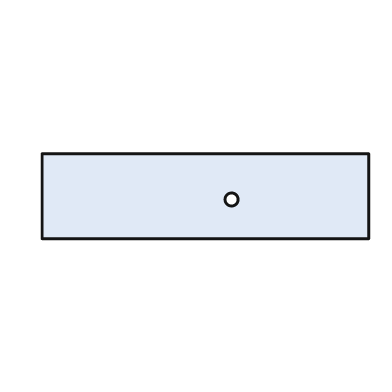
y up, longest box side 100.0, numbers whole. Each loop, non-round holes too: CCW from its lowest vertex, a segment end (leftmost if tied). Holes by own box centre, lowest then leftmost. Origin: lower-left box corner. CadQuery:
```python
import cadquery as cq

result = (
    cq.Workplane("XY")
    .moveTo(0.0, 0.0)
    .lineTo(100.0, 0.0)
    .lineTo(100.0, 26.0)
    .lineTo(0.0, 26.0)
    .close()
    .moveTo(58.0, 12.0)
    .circle(2.0)
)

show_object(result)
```